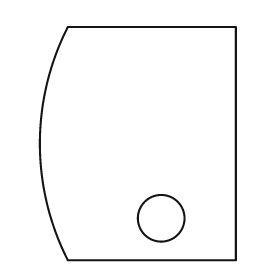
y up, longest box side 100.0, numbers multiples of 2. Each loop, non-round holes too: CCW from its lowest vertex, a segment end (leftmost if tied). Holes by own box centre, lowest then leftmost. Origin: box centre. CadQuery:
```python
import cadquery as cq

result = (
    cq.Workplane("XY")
    .moveTo(-30.0, -50.0)
    .lineTo(42.0, -50.0)
    .lineTo(42.0, 50.0)
    .lineTo(-30.0, 50.0)
    .threePointArc((-42.0, 0.0), (-30.0, -50.0))
    .close()
    .moveTo(10.0, -32.0)
    .circle(10.0)
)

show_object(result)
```